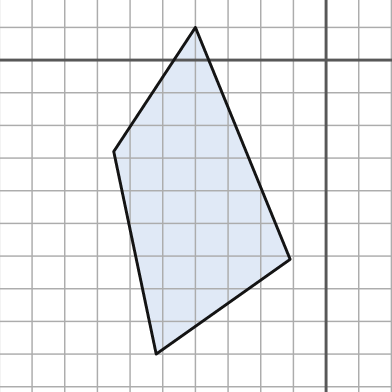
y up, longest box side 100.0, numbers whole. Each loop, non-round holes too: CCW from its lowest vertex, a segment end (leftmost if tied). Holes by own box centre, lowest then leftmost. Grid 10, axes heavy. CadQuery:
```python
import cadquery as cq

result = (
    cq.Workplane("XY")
    .moveTo(-52.0, -90.0)
    .lineTo(-11.0, -61.0)
    .lineTo(-40.0, 10.0)
    .lineTo(-65.0, -28.0)
    .close()
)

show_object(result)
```